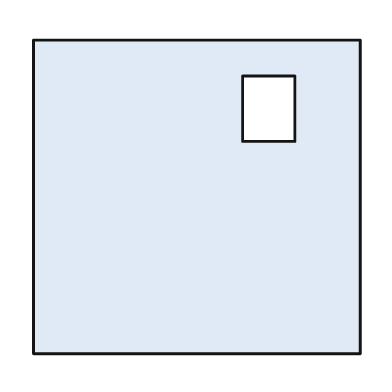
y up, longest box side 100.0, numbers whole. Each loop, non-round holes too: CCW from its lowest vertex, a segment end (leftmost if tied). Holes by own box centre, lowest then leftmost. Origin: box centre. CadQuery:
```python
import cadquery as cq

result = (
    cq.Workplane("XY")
    .moveTo(-50.0, -48.0)
    .lineTo(50.0, -48.0)
    .lineTo(50.0, 48.0)
    .lineTo(-50.0, 48.0)
    .close()
    .moveTo(14.0, 17.0)
    .lineTo(30.0, 17.0)
    .lineTo(30.0, 37.0)
    .lineTo(14.0, 37.0)
    .close()
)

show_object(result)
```